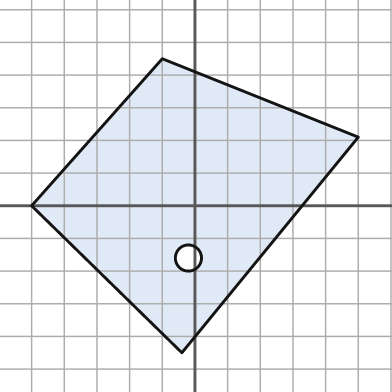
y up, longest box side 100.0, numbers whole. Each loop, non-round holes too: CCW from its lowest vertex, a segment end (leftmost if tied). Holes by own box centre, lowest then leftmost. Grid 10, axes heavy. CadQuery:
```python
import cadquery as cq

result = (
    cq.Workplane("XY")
    .moveTo(-4.0, -45.0)
    .lineTo(50.0, 21.0)
    .lineTo(-10.0, 45.0)
    .lineTo(-50.0, 0.0)
    .close()
    .moveTo(-2.0, -16.0)
    .circle(4.0)
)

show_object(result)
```